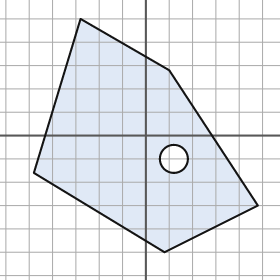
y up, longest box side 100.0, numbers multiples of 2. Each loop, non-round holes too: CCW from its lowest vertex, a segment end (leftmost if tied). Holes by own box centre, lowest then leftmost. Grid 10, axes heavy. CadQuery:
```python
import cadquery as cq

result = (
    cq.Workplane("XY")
    .moveTo(8.0, -50.0)
    .lineTo(48.0, -30.0)
    .lineTo(10.0, 28.0)
    .lineTo(-28.0, 50.0)
    .lineTo(-48.0, -16.0)
    .close()
    .moveTo(12.0, -10.0)
    .circle(6.0)
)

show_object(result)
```